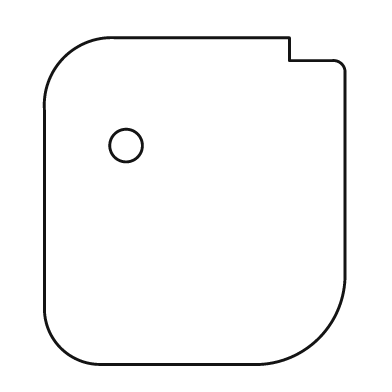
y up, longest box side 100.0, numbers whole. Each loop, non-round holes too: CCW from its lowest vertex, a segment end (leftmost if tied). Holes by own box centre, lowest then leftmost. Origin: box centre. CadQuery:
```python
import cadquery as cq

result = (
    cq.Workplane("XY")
    .moveTo(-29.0, -50.0)
    .lineTo(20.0, -50.0)
    .threePointArc((38.0, -42.0), (46.0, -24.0))
    .lineTo(46.0, 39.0)
    .threePointArc((45.0, 42.0), (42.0, 43.0))
    .lineTo(29.0, 43.0)
    .lineTo(29.0, 50.0)
    .lineTo(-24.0, 50.0)
    .threePointArc((-40.0, 44.0), (-46.0, 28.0))
    .lineTo(-46.0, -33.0)
    .threePointArc((-41.0, -45.0), (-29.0, -50.0))
    .close()
    .moveTo(-21.0, 17.0)
    .circle(5.0)
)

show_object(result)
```